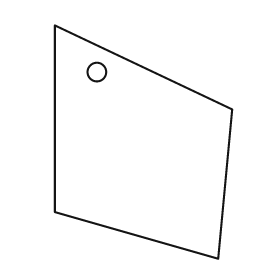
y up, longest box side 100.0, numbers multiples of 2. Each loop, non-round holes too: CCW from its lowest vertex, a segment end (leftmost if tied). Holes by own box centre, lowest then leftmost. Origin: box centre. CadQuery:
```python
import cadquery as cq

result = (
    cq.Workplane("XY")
    .moveTo(32.0, -50.0)
    .lineTo(38.0, 14.0)
    .lineTo(-38.0, 50.0)
    .lineTo(-38.0, -30.0)
    .close()
    .moveTo(-20.0, 30.0)
    .circle(4.0)
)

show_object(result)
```